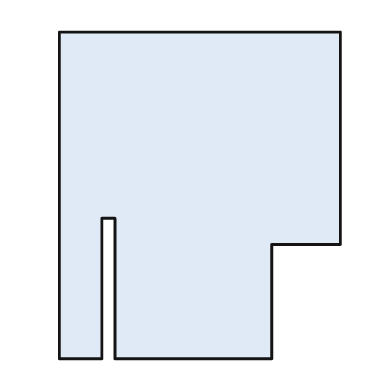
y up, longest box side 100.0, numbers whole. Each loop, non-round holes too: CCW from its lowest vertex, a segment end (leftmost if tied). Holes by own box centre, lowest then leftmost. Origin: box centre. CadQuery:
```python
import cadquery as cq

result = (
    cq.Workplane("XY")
    .moveTo(-43.0, -50.0)
    .lineTo(-30.0, -50.0)
    .lineTo(-30.0, -7.0)
    .lineTo(-26.0, -7.0)
    .lineTo(-26.0, -50.0)
    .lineTo(22.0, -50.0)
    .lineTo(22.0, -15.0)
    .lineTo(43.0, -15.0)
    .lineTo(43.0, 50.0)
    .lineTo(-43.0, 50.0)
    .close()
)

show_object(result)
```